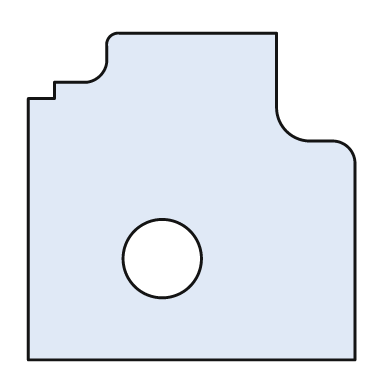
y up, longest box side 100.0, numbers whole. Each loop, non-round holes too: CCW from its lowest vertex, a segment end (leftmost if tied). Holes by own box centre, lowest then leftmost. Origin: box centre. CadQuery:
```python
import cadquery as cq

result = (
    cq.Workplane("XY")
    .moveTo(-50.0, -50.0)
    .lineTo(50.0, -50.0)
    .lineTo(50.0, 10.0)
    .threePointArc((48.0, 15.0), (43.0, 17.0))
    .lineTo(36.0, 17.0)
    .threePointArc((29.0, 20.0), (26.0, 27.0))
    .lineTo(26.0, 50.0)
    .lineTo(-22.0, 50.0)
    .threePointArc((-25.0, 49.0), (-26.0, 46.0))
    .lineTo(-26.0, 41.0)
    .threePointArc((-28.0, 37.0), (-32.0, 35.0))
    .lineTo(-42.0, 35.0)
    .lineTo(-42.0, 30.0)
    .lineTo(-50.0, 30.0)
    .close()
    .moveTo(-9.0, -19.0)
    .circle(12.0)
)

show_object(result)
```